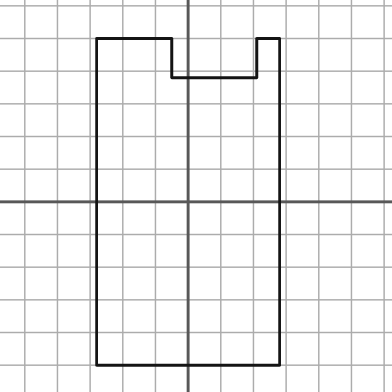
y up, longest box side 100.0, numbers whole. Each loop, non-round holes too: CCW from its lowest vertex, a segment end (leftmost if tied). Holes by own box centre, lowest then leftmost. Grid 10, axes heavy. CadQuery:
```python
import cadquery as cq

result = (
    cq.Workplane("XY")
    .moveTo(-28.0, -50.0)
    .lineTo(28.0, -50.0)
    .lineTo(28.0, 50.0)
    .lineTo(21.0, 50.0)
    .lineTo(21.0, 38.0)
    .lineTo(-5.0, 38.0)
    .lineTo(-5.0, 50.0)
    .lineTo(-28.0, 50.0)
    .close()
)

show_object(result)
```